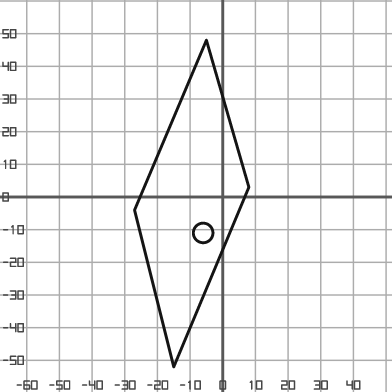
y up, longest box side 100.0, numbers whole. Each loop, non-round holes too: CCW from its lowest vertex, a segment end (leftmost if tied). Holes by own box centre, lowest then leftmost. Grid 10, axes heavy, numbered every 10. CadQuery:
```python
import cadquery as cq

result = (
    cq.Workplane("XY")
    .moveTo(-15.0, -52.0)
    .lineTo(8.0, 3.0)
    .lineTo(-5.0, 48.0)
    .lineTo(-27.0, -4.0)
    .close()
    .moveTo(-6.0, -11.0)
    .circle(3.0)
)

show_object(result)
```